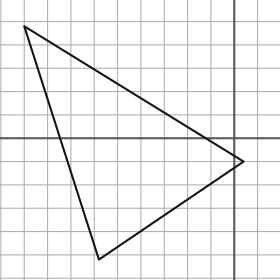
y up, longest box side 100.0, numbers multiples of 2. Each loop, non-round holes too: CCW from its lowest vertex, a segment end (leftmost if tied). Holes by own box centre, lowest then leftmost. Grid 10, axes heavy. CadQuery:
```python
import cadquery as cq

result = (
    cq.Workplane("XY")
    .moveTo(-58.0, -52.0)
    .lineTo(4.0, -10.0)
    .lineTo(-90.0, 48.0)
    .close()
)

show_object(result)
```